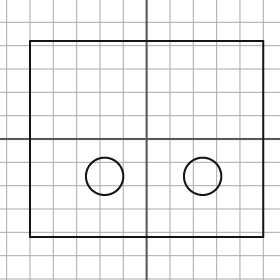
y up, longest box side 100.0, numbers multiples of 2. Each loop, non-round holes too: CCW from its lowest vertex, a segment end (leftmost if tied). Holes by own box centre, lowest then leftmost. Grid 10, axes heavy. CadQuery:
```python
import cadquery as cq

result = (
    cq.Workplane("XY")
    .moveTo(-50.0, -42.0)
    .lineTo(50.0, -42.0)
    .lineTo(50.0, 42.0)
    .lineTo(-50.0, 42.0)
    .close()
    .moveTo(-18.0, -16.0)
    .circle(8.0)
    .moveTo(24.0, -16.0)
    .circle(8.0)
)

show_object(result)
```